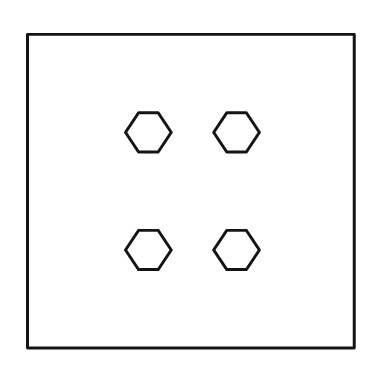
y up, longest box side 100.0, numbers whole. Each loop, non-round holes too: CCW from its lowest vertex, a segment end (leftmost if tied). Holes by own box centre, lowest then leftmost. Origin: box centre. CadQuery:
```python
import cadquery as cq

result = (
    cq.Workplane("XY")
    .moveTo(-50.0, -48.0)
    .lineTo(50.0, -48.0)
    .lineTo(50.0, 48.0)
    .lineTo(-50.0, 48.0)
    .close()
    .moveTo(-16.0, -24.0)
    .lineTo(-10.0, -24.0)
    .lineTo(-6.0, -18.0)
    .lineTo(-10.0, -12.0)
    .lineTo(-16.0, -12.0)
    .lineTo(-20.0, -18.0)
    .close()
    .moveTo(11.0, -24.0)
    .lineTo(17.0, -24.0)
    .lineTo(21.0, -18.0)
    .lineTo(17.0, -12.0)
    .lineTo(11.0, -12.0)
    .lineTo(7.0, -18.0)
    .close()
    .moveTo(-16.0, 12.0)
    .lineTo(-10.0, 12.0)
    .lineTo(-6.0, 18.0)
    .lineTo(-10.0, 24.0)
    .lineTo(-16.0, 24.0)
    .lineTo(-20.0, 18.0)
    .close()
    .moveTo(11.0, 12.0)
    .lineTo(17.0, 12.0)
    .lineTo(21.0, 18.0)
    .lineTo(17.0, 24.0)
    .lineTo(11.0, 24.0)
    .lineTo(7.0, 18.0)
    .close()
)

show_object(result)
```